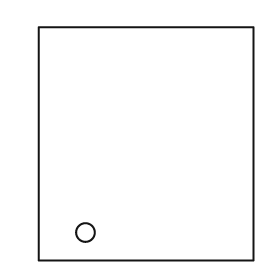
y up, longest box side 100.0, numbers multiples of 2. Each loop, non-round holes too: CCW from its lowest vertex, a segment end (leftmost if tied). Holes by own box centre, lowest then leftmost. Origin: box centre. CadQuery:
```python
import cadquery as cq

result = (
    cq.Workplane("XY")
    .moveTo(-46.0, -50.0)
    .lineTo(46.0, -50.0)
    .lineTo(46.0, 50.0)
    .lineTo(-46.0, 50.0)
    .close()
    .moveTo(-26.0, -38.0)
    .circle(4.0)
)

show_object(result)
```